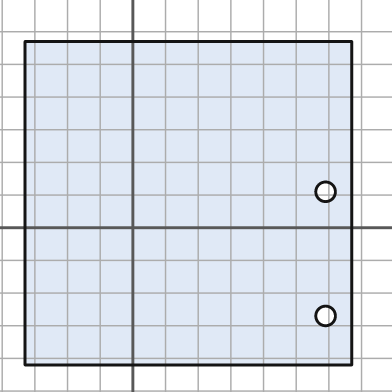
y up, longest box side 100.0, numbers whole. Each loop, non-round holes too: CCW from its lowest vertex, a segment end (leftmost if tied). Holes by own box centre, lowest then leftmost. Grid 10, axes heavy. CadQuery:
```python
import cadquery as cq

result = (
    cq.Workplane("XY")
    .moveTo(-33.0, -42.0)
    .lineTo(67.0, -42.0)
    .lineTo(67.0, 57.0)
    .lineTo(-33.0, 57.0)
    .close()
    .moveTo(59.0, -27.0)
    .circle(3.0)
    .moveTo(59.0, 11.0)
    .circle(3.0)
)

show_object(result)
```